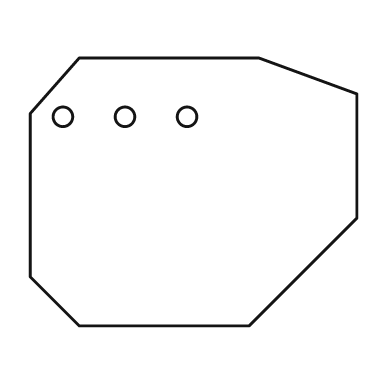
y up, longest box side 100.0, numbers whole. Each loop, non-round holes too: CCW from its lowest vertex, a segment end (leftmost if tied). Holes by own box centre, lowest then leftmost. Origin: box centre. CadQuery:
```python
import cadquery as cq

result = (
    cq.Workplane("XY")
    .moveTo(-35.0, -41.0)
    .lineTo(17.0, -41.0)
    .lineTo(50.0, -8.0)
    .lineTo(50.0, 30.0)
    .lineTo(20.0, 41.0)
    .lineTo(-35.0, 41.0)
    .lineTo(-50.0, 24.0)
    .lineTo(-50.0, -26.0)
    .close()
    .moveTo(-40.0, 23.0)
    .circle(3.0)
    .moveTo(-21.0, 23.0)
    .circle(3.0)
    .moveTo(-2.0, 23.0)
    .circle(3.0)
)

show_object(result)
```